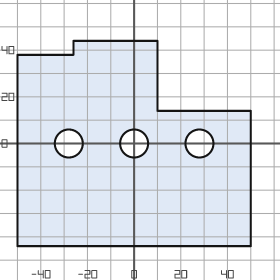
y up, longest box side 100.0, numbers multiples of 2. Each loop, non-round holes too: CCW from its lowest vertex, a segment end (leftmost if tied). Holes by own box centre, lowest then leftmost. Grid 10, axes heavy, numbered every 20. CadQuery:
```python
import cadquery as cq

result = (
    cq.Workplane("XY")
    .moveTo(-50.0, -44.0)
    .lineTo(50.0, -44.0)
    .lineTo(50.0, 14.0)
    .lineTo(10.0, 14.0)
    .lineTo(10.0, 44.0)
    .lineTo(-26.0, 44.0)
    .lineTo(-26.0, 38.0)
    .lineTo(-50.0, 38.0)
    .close()
    .moveTo(-28.0, 0.0)
    .circle(6.0)
    .moveTo(0.0, 0.0)
    .circle(6.0)
    .moveTo(28.0, 0.0)
    .circle(6.0)
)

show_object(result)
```